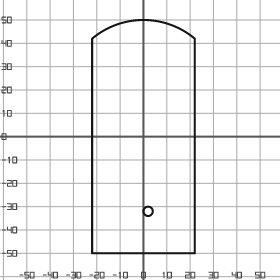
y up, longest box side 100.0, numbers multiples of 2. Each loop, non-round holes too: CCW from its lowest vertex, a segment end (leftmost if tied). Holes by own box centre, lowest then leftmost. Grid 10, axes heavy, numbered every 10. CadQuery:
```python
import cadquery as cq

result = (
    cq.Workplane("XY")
    .moveTo(-22.0, -50.0)
    .lineTo(22.0, -50.0)
    .lineTo(22.0, 42.0)
    .threePointArc((0.0, 50.0), (-22.0, 42.0))
    .close()
    .moveTo(2.0, -32.0)
    .circle(2.0)
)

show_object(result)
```